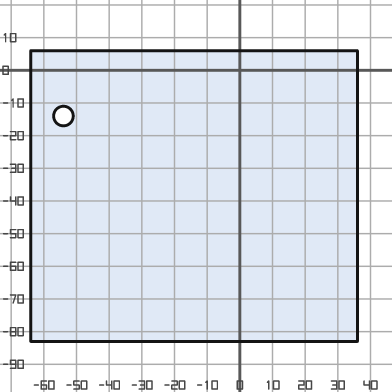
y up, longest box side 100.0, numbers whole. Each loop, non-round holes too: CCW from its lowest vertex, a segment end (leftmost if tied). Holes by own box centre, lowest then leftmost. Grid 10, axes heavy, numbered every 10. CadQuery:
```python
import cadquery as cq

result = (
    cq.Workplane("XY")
    .moveTo(-64.0, -83.0)
    .lineTo(36.0, -83.0)
    .lineTo(36.0, 6.0)
    .lineTo(-64.0, 6.0)
    .close()
    .moveTo(-54.0, -14.0)
    .circle(3.0)
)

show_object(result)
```